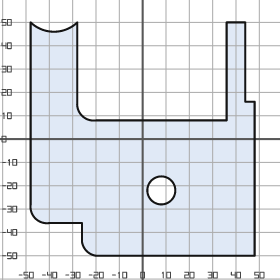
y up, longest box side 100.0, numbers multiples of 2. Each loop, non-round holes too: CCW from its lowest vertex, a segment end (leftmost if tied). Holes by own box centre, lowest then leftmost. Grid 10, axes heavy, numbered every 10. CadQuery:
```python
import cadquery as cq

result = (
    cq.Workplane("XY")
    .moveTo(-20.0, -50.0)
    .lineTo(48.0, -50.0)
    .lineTo(48.0, 16.0)
    .lineTo(44.0, 16.0)
    .lineTo(44.0, 50.0)
    .lineTo(36.0, 50.0)
    .lineTo(36.0, 8.0)
    .lineTo(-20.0, 8.0)
    .threePointArc((-26.0, 10.0), (-28.0, 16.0))
    .lineTo(-28.0, 50.0)
    .threePointArc((-38.0, 46.0), (-48.0, 50.0))
    .lineTo(-48.0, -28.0)
    .threePointArc((-46.0, -34.0), (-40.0, -36.0))
    .lineTo(-26.0, -36.0)
    .lineTo(-26.0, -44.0)
    .threePointArc((-24.0, -48.0), (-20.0, -50.0))
    .close()
    .moveTo(8.0, -22.0)
    .circle(6.0)
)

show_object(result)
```